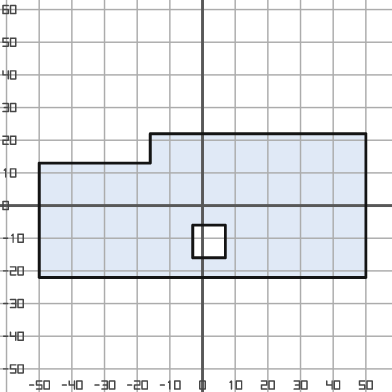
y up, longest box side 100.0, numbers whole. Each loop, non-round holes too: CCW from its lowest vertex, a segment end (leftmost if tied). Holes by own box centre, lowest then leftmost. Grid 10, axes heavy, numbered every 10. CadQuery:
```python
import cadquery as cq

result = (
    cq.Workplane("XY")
    .moveTo(-50.0, -22.0)
    .lineTo(50.0, -22.0)
    .lineTo(50.0, 22.0)
    .lineTo(-16.0, 22.0)
    .lineTo(-16.0, 13.0)
    .lineTo(-50.0, 13.0)
    .close()
    .moveTo(-3.0, -16.0)
    .lineTo(7.0, -16.0)
    .lineTo(7.0, -6.0)
    .lineTo(-3.0, -6.0)
    .close()
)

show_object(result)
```